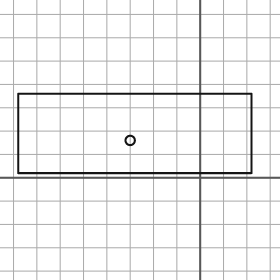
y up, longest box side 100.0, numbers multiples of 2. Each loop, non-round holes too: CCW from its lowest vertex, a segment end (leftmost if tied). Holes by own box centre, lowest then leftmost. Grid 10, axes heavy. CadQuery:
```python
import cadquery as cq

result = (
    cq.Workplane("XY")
    .moveTo(-78.0, 2.0)
    .lineTo(22.0, 2.0)
    .lineTo(22.0, 36.0)
    .lineTo(-78.0, 36.0)
    .close()
    .moveTo(-30.0, 16.0)
    .circle(2.0)
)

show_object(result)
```